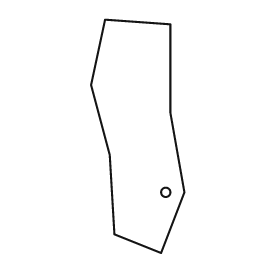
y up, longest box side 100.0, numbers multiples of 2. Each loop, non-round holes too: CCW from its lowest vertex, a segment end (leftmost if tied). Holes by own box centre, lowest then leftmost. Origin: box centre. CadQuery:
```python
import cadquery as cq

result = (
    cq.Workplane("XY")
    .moveTo(10.0, -50.0)
    .lineTo(20.0, -24.0)
    .lineTo(14.0, 10.0)
    .lineTo(14.0, 48.0)
    .lineTo(-14.0, 50.0)
    .lineTo(-20.0, 22.0)
    .lineTo(-12.0, -8.0)
    .lineTo(-10.0, -42.0)
    .close()
    .moveTo(12.0, -24.0)
    .circle(2.0)
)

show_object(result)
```